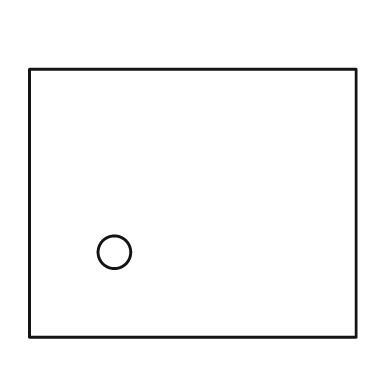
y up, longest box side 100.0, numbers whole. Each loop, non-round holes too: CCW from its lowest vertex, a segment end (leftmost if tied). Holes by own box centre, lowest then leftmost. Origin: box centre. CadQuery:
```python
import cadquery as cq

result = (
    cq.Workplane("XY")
    .moveTo(-50.0, -41.0)
    .lineTo(50.0, -41.0)
    .lineTo(50.0, 41.0)
    .lineTo(-50.0, 41.0)
    .close()
    .moveTo(-24.0, -15.0)
    .circle(5.0)
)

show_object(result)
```